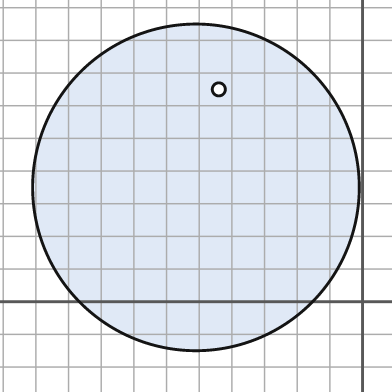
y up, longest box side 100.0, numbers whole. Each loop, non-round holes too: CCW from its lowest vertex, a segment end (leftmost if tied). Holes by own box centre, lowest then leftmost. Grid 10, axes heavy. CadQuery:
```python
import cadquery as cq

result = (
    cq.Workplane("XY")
    .moveTo(-51.0, 35.0)
    .circle(50.0)
    .moveTo(-44.0, 65.0)
    .circle(2.0)
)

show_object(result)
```